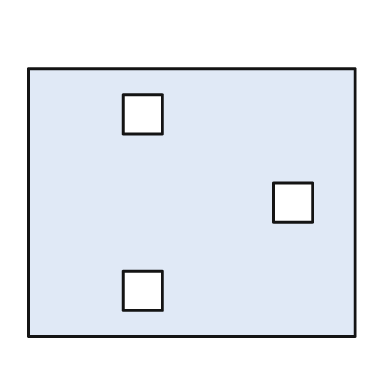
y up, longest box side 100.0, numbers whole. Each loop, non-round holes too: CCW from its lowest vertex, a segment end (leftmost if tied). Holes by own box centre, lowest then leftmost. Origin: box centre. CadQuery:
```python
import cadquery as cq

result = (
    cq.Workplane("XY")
    .moveTo(-50.0, -41.0)
    .lineTo(50.0, -41.0)
    .lineTo(50.0, 41.0)
    .lineTo(-50.0, 41.0)
    .close()
    .moveTo(-21.0, -33.0)
    .lineTo(-9.0, -33.0)
    .lineTo(-9.0, -21.0)
    .lineTo(-21.0, -21.0)
    .close()
    .moveTo(25.0, -6.0)
    .lineTo(37.0, -6.0)
    .lineTo(37.0, 6.0)
    .lineTo(25.0, 6.0)
    .close()
    .moveTo(-21.0, 21.0)
    .lineTo(-9.0, 21.0)
    .lineTo(-9.0, 33.0)
    .lineTo(-21.0, 33.0)
    .close()
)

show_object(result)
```